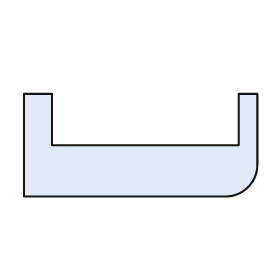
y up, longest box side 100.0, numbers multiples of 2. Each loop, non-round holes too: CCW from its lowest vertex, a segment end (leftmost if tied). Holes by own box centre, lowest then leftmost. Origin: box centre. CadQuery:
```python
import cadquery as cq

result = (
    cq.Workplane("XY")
    .moveTo(-50.0, -22.0)
    .lineTo(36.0, -22.0)
    .threePointArc((46.0, -18.0), (50.0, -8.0))
    .lineTo(50.0, 22.0)
    .lineTo(42.0, 22.0)
    .lineTo(42.0, 0.0)
    .lineTo(-38.0, 0.0)
    .lineTo(-38.0, 22.0)
    .lineTo(-50.0, 22.0)
    .close()
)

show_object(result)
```